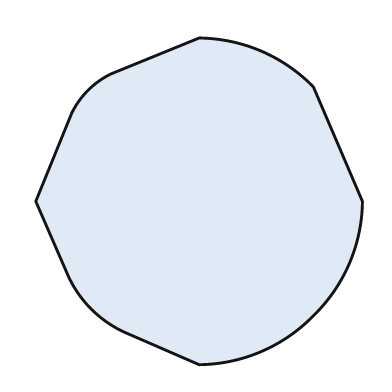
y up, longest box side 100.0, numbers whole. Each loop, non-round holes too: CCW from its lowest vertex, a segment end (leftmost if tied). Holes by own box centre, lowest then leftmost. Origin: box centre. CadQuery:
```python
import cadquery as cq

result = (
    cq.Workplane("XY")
    .moveTo(0.0, -50.0)
    .threePointArc((19.0, -46.0), (35.0, -35.0))
    .threePointArc((46.0, -19.0), (50.0, 0.0))
    .lineTo(35.0, 35.0)
    .threePointArc((19.0, 46.0), (0.0, 50.0))
    .lineTo(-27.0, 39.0)
    .threePointArc((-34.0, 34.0), (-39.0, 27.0))
    .lineTo(-50.0, 0.0)
    .lineTo(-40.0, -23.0)
    .threePointArc((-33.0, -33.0), (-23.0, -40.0))
    .close()
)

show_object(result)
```